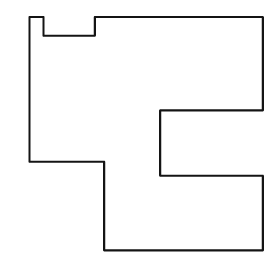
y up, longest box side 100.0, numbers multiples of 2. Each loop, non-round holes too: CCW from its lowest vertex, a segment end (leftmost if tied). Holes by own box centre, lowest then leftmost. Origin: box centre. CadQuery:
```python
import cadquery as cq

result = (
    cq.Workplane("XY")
    .moveTo(-18.0, -50.0)
    .lineTo(50.0, -50.0)
    .lineTo(50.0, -18.0)
    .lineTo(6.0, -18.0)
    .lineTo(6.0, 10.0)
    .lineTo(50.0, 10.0)
    .lineTo(50.0, 50.0)
    .lineTo(-22.0, 50.0)
    .lineTo(-22.0, 42.0)
    .lineTo(-44.0, 42.0)
    .lineTo(-44.0, 50.0)
    .lineTo(-50.0, 50.0)
    .lineTo(-50.0, -12.0)
    .lineTo(-18.0, -12.0)
    .close()
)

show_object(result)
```